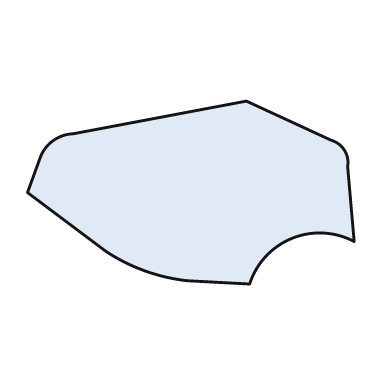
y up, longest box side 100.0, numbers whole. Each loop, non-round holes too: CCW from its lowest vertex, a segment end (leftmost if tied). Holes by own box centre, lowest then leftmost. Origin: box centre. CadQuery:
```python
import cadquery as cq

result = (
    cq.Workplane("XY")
    .moveTo(18.0, -28.0)
    .threePointArc((31.0, -14.0), (50.0, -15.0))
    .lineTo(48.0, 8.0)
    .threePointArc((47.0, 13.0), (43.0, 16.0))
    .lineTo(17.0, 28.0)
    .lineTo(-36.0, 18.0)
    .threePointArc((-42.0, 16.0), (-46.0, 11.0))
    .lineTo(-50.0, 0.0)
    .lineTo(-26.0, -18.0)
    .threePointArc((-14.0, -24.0), (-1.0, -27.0))
    .close()
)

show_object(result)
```